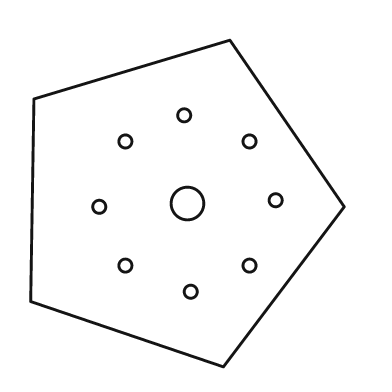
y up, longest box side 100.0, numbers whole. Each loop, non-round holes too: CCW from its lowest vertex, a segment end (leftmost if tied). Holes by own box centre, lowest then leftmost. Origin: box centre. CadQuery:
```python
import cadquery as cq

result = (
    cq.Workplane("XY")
    .moveTo(11.0, -50.0)
    .lineTo(48.0, -1.0)
    .lineTo(13.0, 50.0)
    .lineTo(-47.0, 32.0)
    .lineTo(-48.0, -30.0)
    .close()
    .moveTo(1.0, -27.0)
    .circle(2.0)
    .moveTo(-19.0, -19.0)
    .circle(2.0)
    .moveTo(19.0, -19.0)
    .circle(2.0)
    .moveTo(-27.0, -1.0)
    .circle(2.0)
    .moveTo(0.0, 0.0)
    .circle(5.0)
    .moveTo(27.0, 1.0)
    .circle(2.0)
    .moveTo(-19.0, 19.0)
    .circle(2.0)
    .moveTo(19.0, 19.0)
    .circle(2.0)
    .moveTo(-1.0, 27.0)
    .circle(2.0)
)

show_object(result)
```